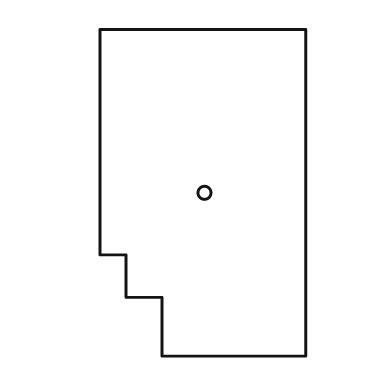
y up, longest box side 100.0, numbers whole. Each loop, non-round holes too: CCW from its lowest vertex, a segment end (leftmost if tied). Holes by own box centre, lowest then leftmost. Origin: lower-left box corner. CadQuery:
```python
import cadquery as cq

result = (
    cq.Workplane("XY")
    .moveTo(19.0, 0.0)
    .lineTo(63.0, 0.0)
    .lineTo(63.0, 100.0)
    .lineTo(0.0, 100.0)
    .lineTo(0.0, 31.0)
    .lineTo(8.0, 31.0)
    .lineTo(8.0, 18.0)
    .lineTo(19.0, 18.0)
    .close()
    .moveTo(32.0, 50.0)
    .circle(2.0)
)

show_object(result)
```